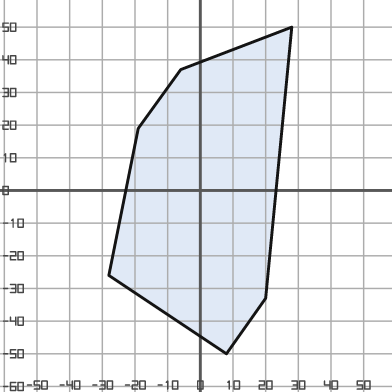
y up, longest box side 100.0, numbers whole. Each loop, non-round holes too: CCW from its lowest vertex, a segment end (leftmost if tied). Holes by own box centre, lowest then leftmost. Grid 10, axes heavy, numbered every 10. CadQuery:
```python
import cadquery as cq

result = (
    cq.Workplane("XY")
    .moveTo(8.0, -50.0)
    .lineTo(20.0, -33.0)
    .lineTo(28.0, 50.0)
    .lineTo(-6.0, 37.0)
    .lineTo(-19.0, 19.0)
    .lineTo(-28.0, -26.0)
    .close()
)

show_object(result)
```